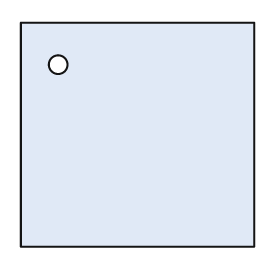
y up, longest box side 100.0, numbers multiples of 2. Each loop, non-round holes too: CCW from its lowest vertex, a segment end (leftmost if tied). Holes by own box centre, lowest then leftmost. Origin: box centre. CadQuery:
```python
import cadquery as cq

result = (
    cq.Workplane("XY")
    .moveTo(-50.0, -48.0)
    .lineTo(50.0, -48.0)
    .lineTo(50.0, 48.0)
    .lineTo(-50.0, 48.0)
    .close()
    .moveTo(-34.0, 30.0)
    .circle(4.0)
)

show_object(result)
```